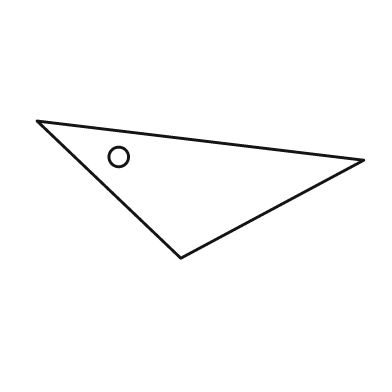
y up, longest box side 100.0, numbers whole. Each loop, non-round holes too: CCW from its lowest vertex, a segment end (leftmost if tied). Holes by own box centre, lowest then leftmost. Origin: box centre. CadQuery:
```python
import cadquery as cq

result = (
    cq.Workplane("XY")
    .moveTo(-6.0, -21.0)
    .lineTo(50.0, 9.0)
    .lineTo(-50.0, 21.0)
    .close()
    .moveTo(-25.0, 10.0)
    .circle(3.0)
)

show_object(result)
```